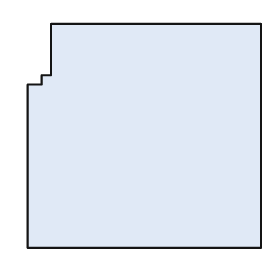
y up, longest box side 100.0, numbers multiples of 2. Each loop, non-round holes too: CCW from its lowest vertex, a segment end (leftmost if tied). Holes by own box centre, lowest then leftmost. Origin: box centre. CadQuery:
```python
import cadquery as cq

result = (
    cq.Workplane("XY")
    .moveTo(-50.0, -48.0)
    .lineTo(50.0, -48.0)
    .lineTo(50.0, 48.0)
    .lineTo(-40.0, 48.0)
    .lineTo(-40.0, 26.0)
    .lineTo(-44.0, 26.0)
    .lineTo(-44.0, 22.0)
    .lineTo(-50.0, 22.0)
    .close()
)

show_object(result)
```